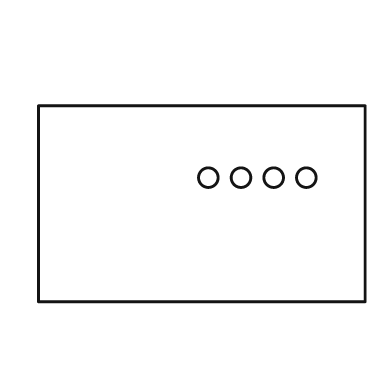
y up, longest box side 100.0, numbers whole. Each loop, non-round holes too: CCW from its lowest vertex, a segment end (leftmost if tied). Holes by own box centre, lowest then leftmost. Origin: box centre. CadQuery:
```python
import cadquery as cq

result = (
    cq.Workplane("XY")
    .moveTo(-50.0, -30.0)
    .lineTo(50.0, -30.0)
    .lineTo(50.0, 30.0)
    .lineTo(-50.0, 30.0)
    .close()
    .moveTo(2.0, 8.0)
    .circle(3.0)
    .moveTo(12.0, 8.0)
    .circle(3.0)
    .moveTo(22.0, 8.0)
    .circle(3.0)
    .moveTo(32.0, 8.0)
    .circle(3.0)
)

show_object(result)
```